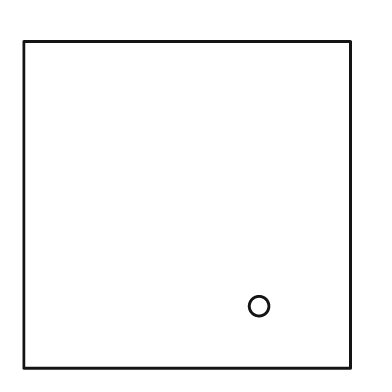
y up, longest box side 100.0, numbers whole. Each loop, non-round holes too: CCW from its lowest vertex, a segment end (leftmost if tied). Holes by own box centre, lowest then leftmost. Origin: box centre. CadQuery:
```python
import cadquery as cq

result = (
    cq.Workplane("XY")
    .moveTo(-50.0, -50.0)
    .lineTo(50.0, -50.0)
    .lineTo(50.0, 50.0)
    .lineTo(-50.0, 50.0)
    .close()
    .moveTo(22.0, -31.0)
    .circle(3.0)
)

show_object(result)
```